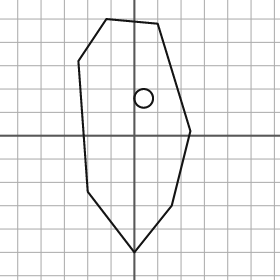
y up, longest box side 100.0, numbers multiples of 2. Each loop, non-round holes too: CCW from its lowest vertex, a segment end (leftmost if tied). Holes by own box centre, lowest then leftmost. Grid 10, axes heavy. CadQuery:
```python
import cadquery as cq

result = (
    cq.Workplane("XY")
    .moveTo(0.0, -50.0)
    .lineTo(16.0, -30.0)
    .lineTo(24.0, 2.0)
    .lineTo(10.0, 48.0)
    .lineTo(-12.0, 50.0)
    .lineTo(-24.0, 32.0)
    .lineTo(-20.0, -24.0)
    .close()
    .moveTo(4.0, 16.0)
    .circle(4.0)
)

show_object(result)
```